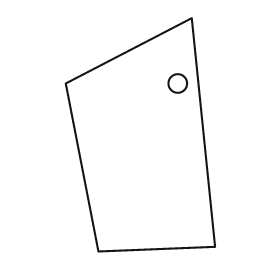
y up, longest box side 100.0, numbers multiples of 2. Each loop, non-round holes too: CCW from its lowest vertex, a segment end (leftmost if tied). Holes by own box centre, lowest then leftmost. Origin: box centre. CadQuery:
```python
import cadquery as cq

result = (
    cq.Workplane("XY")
    .moveTo(-18.0, -50.0)
    .lineTo(32.0, -48.0)
    .lineTo(22.0, 50.0)
    .lineTo(-32.0, 22.0)
    .close()
    .moveTo(16.0, 22.0)
    .circle(4.0)
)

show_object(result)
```